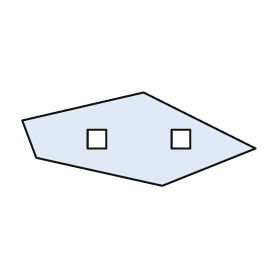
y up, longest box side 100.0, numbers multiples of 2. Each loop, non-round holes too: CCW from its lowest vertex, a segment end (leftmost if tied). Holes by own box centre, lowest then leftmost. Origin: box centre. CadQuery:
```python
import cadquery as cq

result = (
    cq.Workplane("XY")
    .moveTo(10.0, -20.0)
    .lineTo(50.0, -4.0)
    .lineTo(2.0, 20.0)
    .lineTo(-50.0, 8.0)
    .lineTo(-44.0, -8.0)
    .close()
    .moveTo(-22.0, -4.0)
    .lineTo(-14.0, -4.0)
    .lineTo(-14.0, 4.0)
    .lineTo(-22.0, 4.0)
    .close()
    .moveTo(14.0, -4.0)
    .lineTo(22.0, -4.0)
    .lineTo(22.0, 4.0)
    .lineTo(14.0, 4.0)
    .close()
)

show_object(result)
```